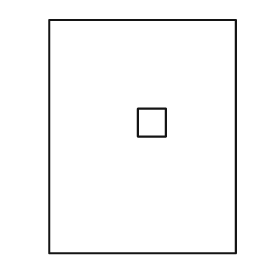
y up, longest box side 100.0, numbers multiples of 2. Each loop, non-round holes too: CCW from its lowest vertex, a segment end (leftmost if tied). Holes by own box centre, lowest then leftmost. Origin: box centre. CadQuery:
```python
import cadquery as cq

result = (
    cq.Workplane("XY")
    .moveTo(-40.0, -50.0)
    .lineTo(40.0, -50.0)
    .lineTo(40.0, 50.0)
    .lineTo(-40.0, 50.0)
    .close()
    .moveTo(-2.0, 0.0)
    .lineTo(10.0, 0.0)
    .lineTo(10.0, 12.0)
    .lineTo(-2.0, 12.0)
    .close()
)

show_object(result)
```